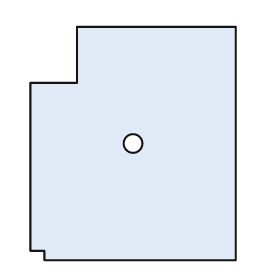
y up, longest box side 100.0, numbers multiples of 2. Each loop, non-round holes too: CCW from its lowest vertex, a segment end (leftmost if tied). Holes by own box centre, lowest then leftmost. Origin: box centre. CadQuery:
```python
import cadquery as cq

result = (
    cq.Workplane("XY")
    .moveTo(-38.0, -50.0)
    .lineTo(44.0, -50.0)
    .lineTo(44.0, 50.0)
    .lineTo(-24.0, 50.0)
    .lineTo(-24.0, 26.0)
    .lineTo(-44.0, 26.0)
    .lineTo(-44.0, -46.0)
    .lineTo(-38.0, -46.0)
    .close()
    .moveTo(0.0, 0.0)
    .circle(4.0)
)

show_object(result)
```